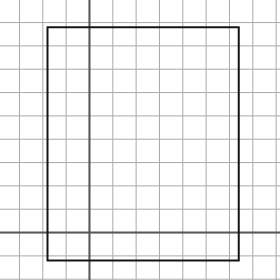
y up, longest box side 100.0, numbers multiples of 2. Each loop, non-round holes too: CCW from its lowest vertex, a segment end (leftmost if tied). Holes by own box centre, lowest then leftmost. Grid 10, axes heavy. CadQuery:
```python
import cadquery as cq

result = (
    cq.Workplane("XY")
    .moveTo(-18.0, -12.0)
    .lineTo(64.0, -12.0)
    .lineTo(64.0, 88.0)
    .lineTo(-18.0, 88.0)
    .close()
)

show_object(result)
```